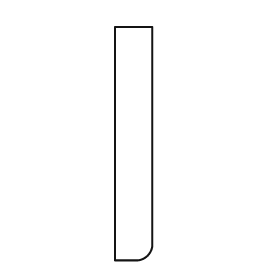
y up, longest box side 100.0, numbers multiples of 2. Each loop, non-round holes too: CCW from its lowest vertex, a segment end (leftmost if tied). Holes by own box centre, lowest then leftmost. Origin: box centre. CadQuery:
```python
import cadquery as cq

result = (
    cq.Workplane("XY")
    .moveTo(-8.0, -50.0)
    .lineTo(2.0, -50.0)
    .threePointArc((6.0, -48.0), (8.0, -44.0))
    .lineTo(8.0, 50.0)
    .lineTo(-8.0, 50.0)
    .close()
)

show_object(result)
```